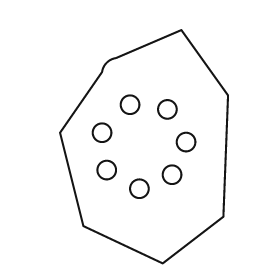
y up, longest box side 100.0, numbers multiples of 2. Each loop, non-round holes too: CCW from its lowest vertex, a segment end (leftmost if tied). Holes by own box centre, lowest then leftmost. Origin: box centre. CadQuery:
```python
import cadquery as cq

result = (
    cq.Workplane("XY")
    .moveTo(8.0, -50.0)
    .lineTo(34.0, -30.0)
    .lineTo(36.0, 22.0)
    .lineTo(16.0, 50.0)
    .lineTo(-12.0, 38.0)
    .threePointArc((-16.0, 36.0), (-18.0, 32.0))
    .lineTo(-36.0, 6.0)
    .lineTo(-26.0, -34.0)
    .close()
    .moveTo(-2.0, -18.0)
    .circle(4.0)
    .moveTo(12.0, -12.0)
    .circle(4.0)
    .moveTo(-16.0, -10.0)
    .circle(4.0)
    .moveTo(18.0, 2.0)
    .circle(4.0)
    .moveTo(-18.0, 6.0)
    .circle(4.0)
    .moveTo(10.0, 16.0)
    .circle(4.0)
    .moveTo(-6.0, 18.0)
    .circle(4.0)
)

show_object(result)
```